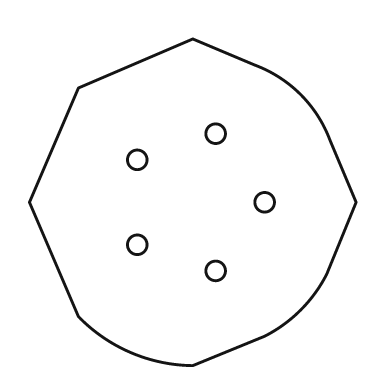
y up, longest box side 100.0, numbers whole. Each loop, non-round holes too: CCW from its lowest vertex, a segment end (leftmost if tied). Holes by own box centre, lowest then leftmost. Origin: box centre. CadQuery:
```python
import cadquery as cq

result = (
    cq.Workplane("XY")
    .moveTo(0.0, -50.0)
    .lineTo(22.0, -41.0)
    .threePointArc((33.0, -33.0), (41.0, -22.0))
    .lineTo(50.0, 0.0)
    .lineTo(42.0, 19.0)
    .threePointArc((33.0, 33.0), (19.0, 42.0))
    .lineTo(0.0, 50.0)
    .lineTo(-35.0, 35.0)
    .lineTo(-50.0, 0.0)
    .lineTo(-35.0, -35.0)
    .threePointArc((-19.0, -46.0), (0.0, -50.0))
    .close()
    .moveTo(7.0, -21.0)
    .circle(3.0)
    .moveTo(-17.0, -13.0)
    .circle(3.0)
    .moveTo(22.0, 0.0)
    .circle(3.0)
    .moveTo(-17.0, 13.0)
    .circle(3.0)
    .moveTo(7.0, 21.0)
    .circle(3.0)
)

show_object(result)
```